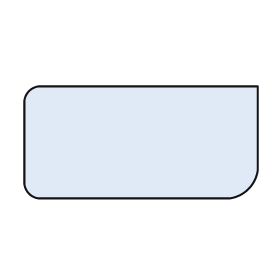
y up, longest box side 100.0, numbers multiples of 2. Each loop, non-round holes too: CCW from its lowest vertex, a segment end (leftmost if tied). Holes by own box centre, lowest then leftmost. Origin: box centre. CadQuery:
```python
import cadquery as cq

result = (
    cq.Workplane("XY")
    .moveTo(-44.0, -24.0)
    .lineTo(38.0, -24.0)
    .threePointArc((46.0, -20.0), (50.0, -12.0))
    .lineTo(50.0, 24.0)
    .lineTo(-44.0, 24.0)
    .threePointArc((-48.0, 22.0), (-50.0, 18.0))
    .lineTo(-50.0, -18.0)
    .threePointArc((-48.0, -22.0), (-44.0, -24.0))
    .close()
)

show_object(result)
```